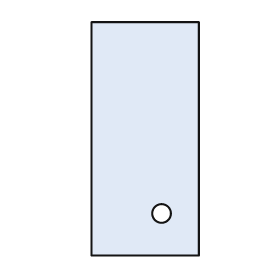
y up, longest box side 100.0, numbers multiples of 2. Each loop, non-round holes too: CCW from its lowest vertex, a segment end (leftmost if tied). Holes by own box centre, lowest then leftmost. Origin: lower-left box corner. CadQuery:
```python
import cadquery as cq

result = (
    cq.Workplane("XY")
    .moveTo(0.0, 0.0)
    .lineTo(46.0, 0.0)
    .lineTo(46.0, 100.0)
    .lineTo(0.0, 100.0)
    .close()
    .moveTo(30.0, 18.0)
    .circle(4.0)
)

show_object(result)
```